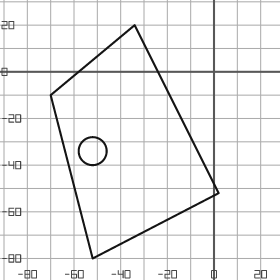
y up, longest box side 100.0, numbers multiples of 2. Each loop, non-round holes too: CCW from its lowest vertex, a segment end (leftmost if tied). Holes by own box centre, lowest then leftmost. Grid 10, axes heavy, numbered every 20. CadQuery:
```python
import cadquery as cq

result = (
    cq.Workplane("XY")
    .moveTo(-52.0, -80.0)
    .lineTo(2.0, -52.0)
    .lineTo(-34.0, 20.0)
    .lineTo(-70.0, -10.0)
    .close()
    .moveTo(-52.0, -34.0)
    .circle(6.0)
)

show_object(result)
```